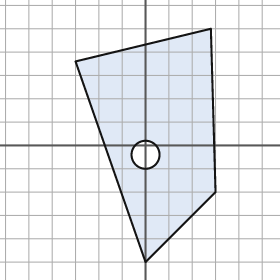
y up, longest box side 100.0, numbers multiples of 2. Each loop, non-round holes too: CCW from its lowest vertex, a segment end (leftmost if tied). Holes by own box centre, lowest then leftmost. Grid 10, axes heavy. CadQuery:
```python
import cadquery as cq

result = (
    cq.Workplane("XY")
    .moveTo(0.0, -50.0)
    .lineTo(30.0, -20.0)
    .lineTo(28.0, 50.0)
    .lineTo(-30.0, 36.0)
    .close()
    .moveTo(0.0, -4.0)
    .circle(6.0)
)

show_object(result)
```